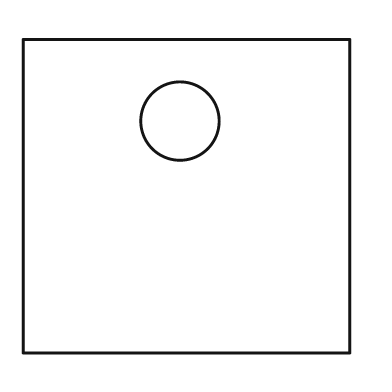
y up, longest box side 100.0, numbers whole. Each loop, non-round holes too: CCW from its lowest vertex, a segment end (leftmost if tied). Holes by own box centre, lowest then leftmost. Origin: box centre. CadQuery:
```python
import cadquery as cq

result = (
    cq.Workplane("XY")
    .moveTo(-50.0, -48.0)
    .lineTo(50.0, -48.0)
    .lineTo(50.0, 48.0)
    .lineTo(-50.0, 48.0)
    .close()
    .moveTo(-2.0, 23.0)
    .circle(12.0)
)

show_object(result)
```